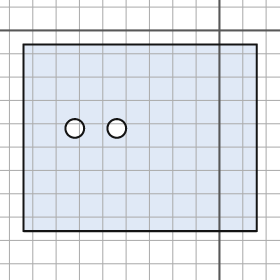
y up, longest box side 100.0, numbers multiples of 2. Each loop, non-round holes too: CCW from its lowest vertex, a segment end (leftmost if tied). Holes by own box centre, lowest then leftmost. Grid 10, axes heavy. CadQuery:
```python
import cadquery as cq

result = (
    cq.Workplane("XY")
    .moveTo(-84.0, -86.0)
    .lineTo(16.0, -86.0)
    .lineTo(16.0, -6.0)
    .lineTo(-84.0, -6.0)
    .close()
    .moveTo(-62.0, -42.0)
    .circle(4.0)
    .moveTo(-44.0, -42.0)
    .circle(4.0)
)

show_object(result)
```